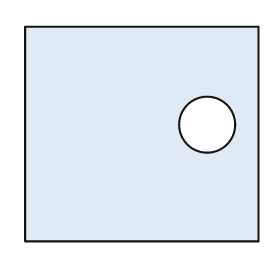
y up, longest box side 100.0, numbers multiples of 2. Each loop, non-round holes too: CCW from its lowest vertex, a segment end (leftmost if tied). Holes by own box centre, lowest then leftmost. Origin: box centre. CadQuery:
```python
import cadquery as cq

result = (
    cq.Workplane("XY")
    .moveTo(-50.0, -46.0)
    .lineTo(50.0, -46.0)
    .lineTo(50.0, 46.0)
    .lineTo(-50.0, 46.0)
    .close()
    .moveTo(28.0, 4.0)
    .circle(12.0)
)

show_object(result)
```